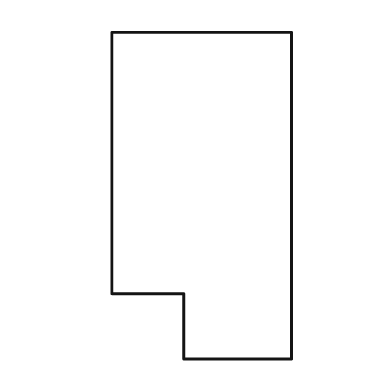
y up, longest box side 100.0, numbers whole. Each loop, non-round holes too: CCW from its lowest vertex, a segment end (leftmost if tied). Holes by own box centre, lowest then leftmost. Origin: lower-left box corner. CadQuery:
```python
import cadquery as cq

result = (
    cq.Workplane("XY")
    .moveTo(22.0, 0.0)
    .lineTo(55.0, 0.0)
    .lineTo(55.0, 100.0)
    .lineTo(0.0, 100.0)
    .lineTo(0.0, 20.0)
    .lineTo(22.0, 20.0)
    .close()
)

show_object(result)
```